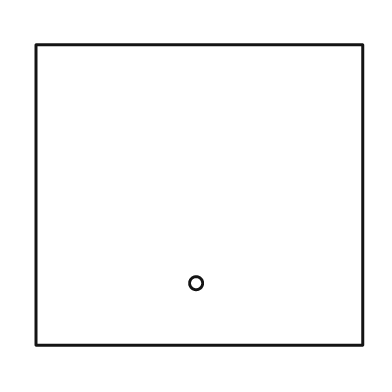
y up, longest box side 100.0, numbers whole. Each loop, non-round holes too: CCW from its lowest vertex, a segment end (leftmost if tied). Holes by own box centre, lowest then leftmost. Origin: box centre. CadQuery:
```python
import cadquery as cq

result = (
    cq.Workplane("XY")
    .moveTo(-50.0, -46.0)
    .lineTo(50.0, -46.0)
    .lineTo(50.0, 46.0)
    .lineTo(-50.0, 46.0)
    .close()
    .moveTo(-1.0, -27.0)
    .circle(2.0)
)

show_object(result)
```